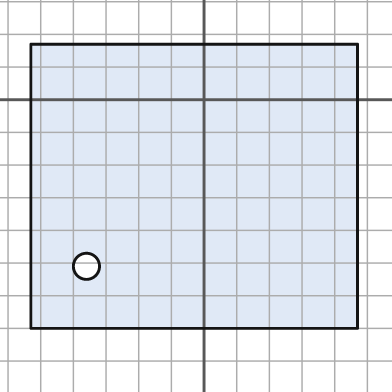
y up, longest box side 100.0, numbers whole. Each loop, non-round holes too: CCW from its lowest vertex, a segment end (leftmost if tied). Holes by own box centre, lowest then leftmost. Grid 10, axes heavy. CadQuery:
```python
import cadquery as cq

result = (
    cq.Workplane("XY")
    .moveTo(-53.0, -70.0)
    .lineTo(47.0, -70.0)
    .lineTo(47.0, 17.0)
    .lineTo(-53.0, 17.0)
    .close()
    .moveTo(-36.0, -51.0)
    .circle(4.0)
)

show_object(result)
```